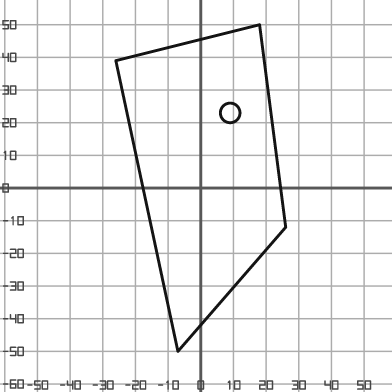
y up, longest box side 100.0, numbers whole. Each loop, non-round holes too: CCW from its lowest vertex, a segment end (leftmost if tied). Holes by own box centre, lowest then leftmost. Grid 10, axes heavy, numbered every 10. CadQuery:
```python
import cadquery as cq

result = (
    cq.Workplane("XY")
    .moveTo(-7.0, -50.0)
    .lineTo(26.0, -12.0)
    .lineTo(18.0, 50.0)
    .lineTo(-26.0, 39.0)
    .close()
    .moveTo(9.0, 23.0)
    .circle(3.0)
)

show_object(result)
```